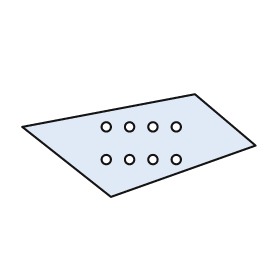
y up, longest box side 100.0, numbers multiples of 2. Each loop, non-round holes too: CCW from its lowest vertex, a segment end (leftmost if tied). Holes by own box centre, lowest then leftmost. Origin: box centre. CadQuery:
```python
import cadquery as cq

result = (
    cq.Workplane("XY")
    .moveTo(-12.0, -22.0)
    .lineTo(50.0, 0.0)
    .lineTo(24.0, 22.0)
    .lineTo(-50.0, 8.0)
    .close()
    .moveTo(-14.0, -6.0)
    .circle(2.0)
    .moveTo(-4.0, -6.0)
    .circle(2.0)
    .moveTo(6.0, -6.0)
    .circle(2.0)
    .moveTo(16.0, -6.0)
    .circle(2.0)
    .moveTo(-14.0, 8.0)
    .circle(2.0)
    .moveTo(-4.0, 8.0)
    .circle(2.0)
    .moveTo(6.0, 8.0)
    .circle(2.0)
    .moveTo(16.0, 8.0)
    .circle(2.0)
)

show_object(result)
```